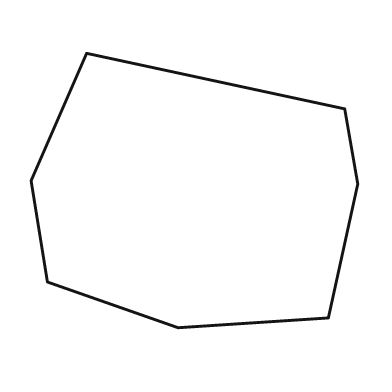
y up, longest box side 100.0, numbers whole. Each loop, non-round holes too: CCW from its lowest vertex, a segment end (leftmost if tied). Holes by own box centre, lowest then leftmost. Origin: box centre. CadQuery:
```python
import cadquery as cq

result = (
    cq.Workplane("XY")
    .moveTo(-5.0, -42.0)
    .lineTo(41.0, -39.0)
    .lineTo(50.0, 2.0)
    .lineTo(46.0, 25.0)
    .lineTo(-33.0, 42.0)
    .lineTo(-50.0, 3.0)
    .lineTo(-45.0, -28.0)
    .close()
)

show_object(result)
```